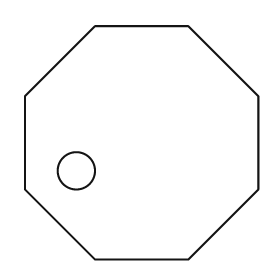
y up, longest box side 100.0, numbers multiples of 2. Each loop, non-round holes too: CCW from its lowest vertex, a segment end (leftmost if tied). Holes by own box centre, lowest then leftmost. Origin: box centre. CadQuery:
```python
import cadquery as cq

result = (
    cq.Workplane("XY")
    .moveTo(-20.0, -50.0)
    .lineTo(20.0, -50.0)
    .lineTo(50.0, -20.0)
    .lineTo(50.0, 20.0)
    .lineTo(20.0, 50.0)
    .lineTo(-20.0, 50.0)
    .lineTo(-50.0, 20.0)
    .lineTo(-50.0, -20.0)
    .close()
    .moveTo(-28.0, -12.0)
    .circle(8.0)
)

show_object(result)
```